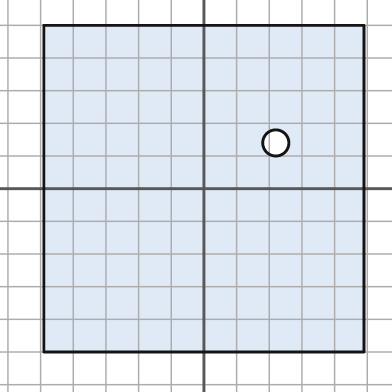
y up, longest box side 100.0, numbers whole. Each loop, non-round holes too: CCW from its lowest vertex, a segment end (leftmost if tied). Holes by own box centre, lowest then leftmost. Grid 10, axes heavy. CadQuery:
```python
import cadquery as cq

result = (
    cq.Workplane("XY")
    .moveTo(-49.0, -50.0)
    .lineTo(49.0, -50.0)
    .lineTo(49.0, 50.0)
    .lineTo(-49.0, 50.0)
    .close()
    .moveTo(22.0, 14.0)
    .circle(4.0)
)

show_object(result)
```